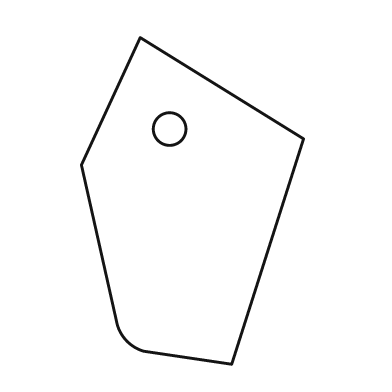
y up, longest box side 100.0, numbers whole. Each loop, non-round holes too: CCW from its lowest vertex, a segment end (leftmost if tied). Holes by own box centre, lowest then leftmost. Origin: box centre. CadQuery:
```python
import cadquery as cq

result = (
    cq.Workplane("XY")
    .moveTo(12.0, -50.0)
    .lineTo(34.0, 19.0)
    .lineTo(-16.0, 50.0)
    .lineTo(-34.0, 11.0)
    .lineTo(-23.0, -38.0)
    .threePointArc((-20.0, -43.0), (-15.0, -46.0))
    .close()
    .moveTo(-7.0, 22.0)
    .circle(5.0)
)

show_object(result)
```